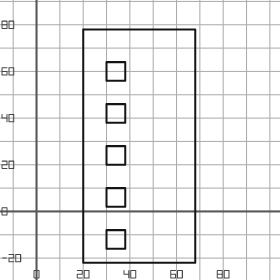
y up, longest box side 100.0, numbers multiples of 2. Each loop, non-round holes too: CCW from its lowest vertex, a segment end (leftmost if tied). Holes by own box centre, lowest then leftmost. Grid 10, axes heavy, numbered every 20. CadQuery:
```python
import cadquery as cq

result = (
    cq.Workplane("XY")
    .moveTo(20.0, -22.0)
    .lineTo(68.0, -22.0)
    .lineTo(68.0, 78.0)
    .lineTo(20.0, 78.0)
    .close()
    .moveTo(30.0, -16.0)
    .lineTo(38.0, -16.0)
    .lineTo(38.0, -8.0)
    .lineTo(30.0, -8.0)
    .close()
    .moveTo(30.0, 2.0)
    .lineTo(38.0, 2.0)
    .lineTo(38.0, 10.0)
    .lineTo(30.0, 10.0)
    .close()
    .moveTo(30.0, 20.0)
    .lineTo(38.0, 20.0)
    .lineTo(38.0, 28.0)
    .lineTo(30.0, 28.0)
    .close()
    .moveTo(30.0, 38.0)
    .lineTo(38.0, 38.0)
    .lineTo(38.0, 46.0)
    .lineTo(30.0, 46.0)
    .close()
    .moveTo(30.0, 56.0)
    .lineTo(38.0, 56.0)
    .lineTo(38.0, 64.0)
    .lineTo(30.0, 64.0)
    .close()
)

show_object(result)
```